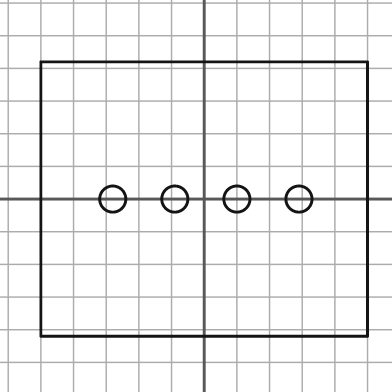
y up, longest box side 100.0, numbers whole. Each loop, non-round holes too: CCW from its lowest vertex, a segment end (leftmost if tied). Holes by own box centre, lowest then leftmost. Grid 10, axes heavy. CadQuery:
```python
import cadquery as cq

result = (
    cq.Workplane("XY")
    .moveTo(-50.0, -42.0)
    .lineTo(50.0, -42.0)
    .lineTo(50.0, 42.0)
    .lineTo(-50.0, 42.0)
    .close()
    .moveTo(-28.0, 0.0)
    .circle(4.0)
    .moveTo(-9.0, 0.0)
    .circle(4.0)
    .moveTo(10.0, 0.0)
    .circle(4.0)
    .moveTo(29.0, 0.0)
    .circle(4.0)
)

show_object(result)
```